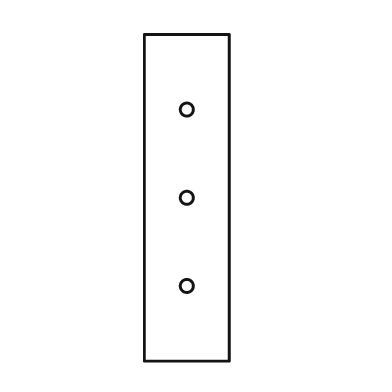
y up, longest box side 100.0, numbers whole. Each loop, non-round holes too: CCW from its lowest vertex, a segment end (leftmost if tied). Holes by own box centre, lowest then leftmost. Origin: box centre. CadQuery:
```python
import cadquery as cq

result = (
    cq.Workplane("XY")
    .moveTo(-13.0, -50.0)
    .lineTo(13.0, -50.0)
    .lineTo(13.0, 50.0)
    .lineTo(-13.0, 50.0)
    .close()
    .moveTo(0.0, -27.0)
    .circle(2.0)
    .moveTo(0.0, 0.0)
    .circle(2.0)
    .moveTo(0.0, 27.0)
    .circle(2.0)
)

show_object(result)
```